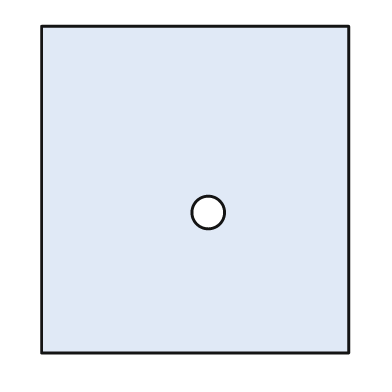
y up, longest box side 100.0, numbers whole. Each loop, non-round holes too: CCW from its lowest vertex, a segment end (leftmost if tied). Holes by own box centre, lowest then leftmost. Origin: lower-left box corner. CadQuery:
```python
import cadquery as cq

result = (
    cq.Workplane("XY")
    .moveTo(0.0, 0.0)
    .lineTo(94.0, 0.0)
    .lineTo(94.0, 100.0)
    .lineTo(0.0, 100.0)
    .close()
    .moveTo(51.0, 43.0)
    .circle(5.0)
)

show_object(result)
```